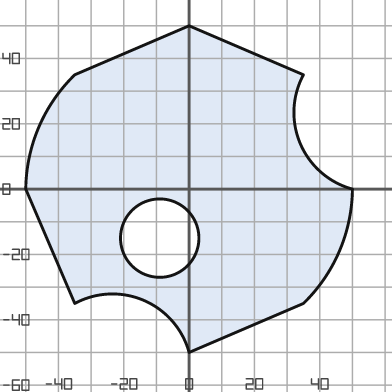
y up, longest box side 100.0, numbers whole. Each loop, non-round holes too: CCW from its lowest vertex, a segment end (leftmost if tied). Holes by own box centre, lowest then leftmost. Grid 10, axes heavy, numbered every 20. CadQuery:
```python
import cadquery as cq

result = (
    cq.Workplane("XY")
    .moveTo(0.0, -50.0)
    .lineTo(35.0, -35.0)
    .threePointArc((46.0, -19.0), (50.0, 0.0))
    .threePointArc((34.0, 14.0), (35.0, 35.0))
    .lineTo(0.0, 50.0)
    .lineTo(-35.0, 35.0)
    .threePointArc((-46.0, 19.0), (-50.0, 0.0))
    .lineTo(-35.0, -35.0)
    .threePointArc((-14.0, -34.0), (0.0, -50.0))
    .close()
    .moveTo(-9.0, -15.0)
    .circle(12.0)
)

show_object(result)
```